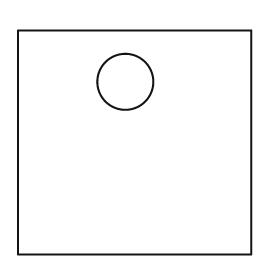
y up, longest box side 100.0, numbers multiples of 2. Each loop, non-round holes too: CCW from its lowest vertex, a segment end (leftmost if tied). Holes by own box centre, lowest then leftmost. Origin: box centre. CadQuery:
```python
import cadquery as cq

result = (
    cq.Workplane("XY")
    .moveTo(-50.0, -48.0)
    .lineTo(50.0, -48.0)
    .lineTo(50.0, 48.0)
    .lineTo(-50.0, 48.0)
    .close()
    .moveTo(-4.0, 26.0)
    .circle(12.0)
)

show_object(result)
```